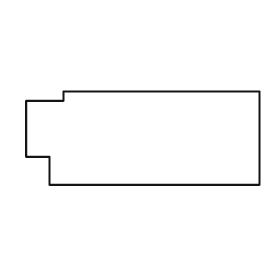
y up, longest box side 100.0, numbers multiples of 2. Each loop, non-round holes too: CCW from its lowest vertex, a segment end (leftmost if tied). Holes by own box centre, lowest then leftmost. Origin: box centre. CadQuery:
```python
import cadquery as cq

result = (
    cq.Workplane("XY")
    .moveTo(-40.0, -20.0)
    .lineTo(50.0, -20.0)
    .lineTo(50.0, 20.0)
    .lineTo(-34.0, 20.0)
    .lineTo(-34.0, 16.0)
    .lineTo(-50.0, 16.0)
    .lineTo(-50.0, -8.0)
    .lineTo(-40.0, -8.0)
    .close()
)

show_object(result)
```